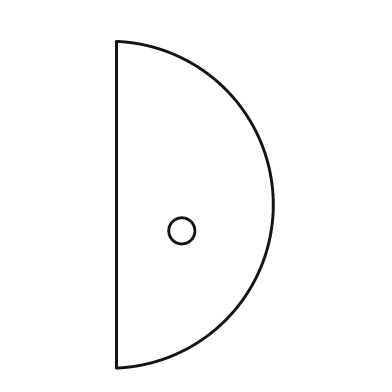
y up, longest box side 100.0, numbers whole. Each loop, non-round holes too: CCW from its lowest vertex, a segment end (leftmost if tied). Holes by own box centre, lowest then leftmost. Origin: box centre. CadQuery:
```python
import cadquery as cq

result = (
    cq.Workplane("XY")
    .moveTo(-24.0, -50.0)
    .threePointArc((24.0, 0.0), (-24.0, 50.0))
    .close()
    .moveTo(-4.0, -8.0)
    .circle(4.0)
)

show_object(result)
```